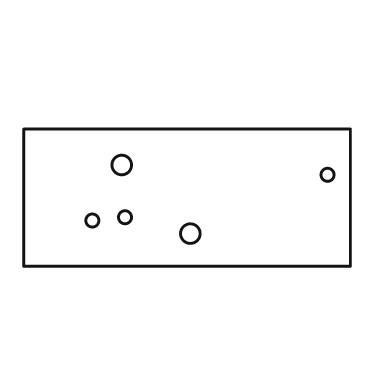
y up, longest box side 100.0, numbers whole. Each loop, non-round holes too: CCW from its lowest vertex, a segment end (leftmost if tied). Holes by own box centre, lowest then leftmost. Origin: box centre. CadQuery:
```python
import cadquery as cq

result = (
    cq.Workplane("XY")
    .moveTo(-50.0, -21.0)
    .lineTo(50.0, -21.0)
    .lineTo(50.0, 21.0)
    .lineTo(-50.0, 21.0)
    .close()
    .moveTo(1.0, -11.0)
    .circle(3.0)
    .moveTo(-29.0, -7.0)
    .circle(2.0)
    .moveTo(-19.0, -6.0)
    .circle(2.0)
    .moveTo(43.0, 7.0)
    .circle(2.0)
    .moveTo(-20.0, 10.0)
    .circle(3.0)
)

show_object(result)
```